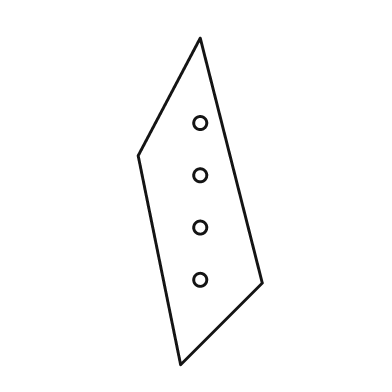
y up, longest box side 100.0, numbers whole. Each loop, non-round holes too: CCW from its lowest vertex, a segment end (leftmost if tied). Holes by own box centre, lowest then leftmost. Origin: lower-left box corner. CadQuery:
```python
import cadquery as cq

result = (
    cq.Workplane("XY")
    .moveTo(13.0, 0.0)
    .lineTo(38.0, 25.0)
    .lineTo(19.0, 100.0)
    .lineTo(0.0, 64.0)
    .close()
    .moveTo(19.0, 26.0)
    .circle(2.0)
    .moveTo(19.0, 42.0)
    .circle(2.0)
    .moveTo(19.0, 58.0)
    .circle(2.0)
    .moveTo(19.0, 74.0)
    .circle(2.0)
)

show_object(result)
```